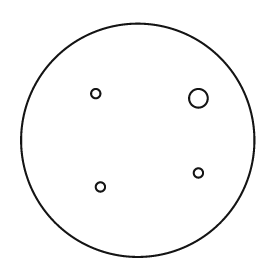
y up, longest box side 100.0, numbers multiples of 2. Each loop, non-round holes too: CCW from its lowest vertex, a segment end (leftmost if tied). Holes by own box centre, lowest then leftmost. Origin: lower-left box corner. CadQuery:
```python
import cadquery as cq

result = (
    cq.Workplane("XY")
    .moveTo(50.0, 50.0)
    .circle(50.0)
    .moveTo(34.0, 30.0)
    .circle(2.0)
    .moveTo(76.0, 36.0)
    .circle(2.0)
    .moveTo(76.0, 68.0)
    .circle(4.0)
    .moveTo(32.0, 70.0)
    .circle(2.0)
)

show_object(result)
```